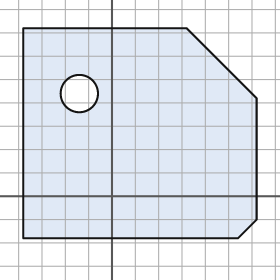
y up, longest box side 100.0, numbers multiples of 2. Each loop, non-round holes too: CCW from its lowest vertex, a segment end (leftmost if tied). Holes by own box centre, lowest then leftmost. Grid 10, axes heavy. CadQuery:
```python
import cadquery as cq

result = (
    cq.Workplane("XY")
    .moveTo(-38.0, -18.0)
    .lineTo(54.0, -18.0)
    .lineTo(62.0, -10.0)
    .lineTo(62.0, 42.0)
    .lineTo(32.0, 72.0)
    .lineTo(-38.0, 72.0)
    .close()
    .moveTo(-14.0, 44.0)
    .circle(8.0)
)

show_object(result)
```